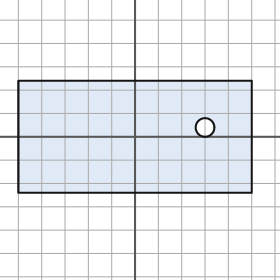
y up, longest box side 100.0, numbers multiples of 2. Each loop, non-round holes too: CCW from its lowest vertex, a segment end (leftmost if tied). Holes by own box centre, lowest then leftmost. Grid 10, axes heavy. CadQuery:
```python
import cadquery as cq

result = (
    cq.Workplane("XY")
    .moveTo(-50.0, -24.0)
    .lineTo(50.0, -24.0)
    .lineTo(50.0, 24.0)
    .lineTo(-50.0, 24.0)
    .close()
    .moveTo(30.0, 4.0)
    .circle(4.0)
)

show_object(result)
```